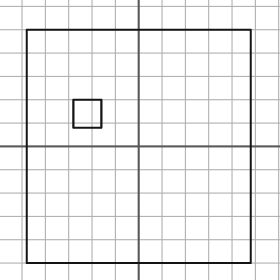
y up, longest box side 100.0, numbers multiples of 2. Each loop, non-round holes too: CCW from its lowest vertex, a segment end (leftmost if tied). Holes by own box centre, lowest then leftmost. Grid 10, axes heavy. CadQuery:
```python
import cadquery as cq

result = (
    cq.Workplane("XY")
    .moveTo(-48.0, -50.0)
    .lineTo(48.0, -50.0)
    .lineTo(48.0, 50.0)
    .lineTo(-48.0, 50.0)
    .close()
    .moveTo(-28.0, 8.0)
    .lineTo(-16.0, 8.0)
    .lineTo(-16.0, 20.0)
    .lineTo(-28.0, 20.0)
    .close()
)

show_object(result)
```